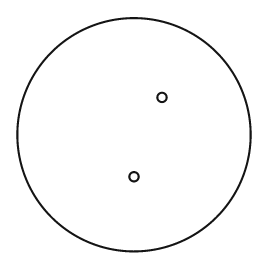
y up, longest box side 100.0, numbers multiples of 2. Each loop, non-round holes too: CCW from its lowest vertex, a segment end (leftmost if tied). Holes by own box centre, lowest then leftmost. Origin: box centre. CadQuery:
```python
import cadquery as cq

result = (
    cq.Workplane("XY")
    .moveTo(0.0, 0.0)
    .circle(50.0)
    .moveTo(0.0, -18.0)
    .circle(2.0)
    .moveTo(12.0, 16.0)
    .circle(2.0)
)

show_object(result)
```